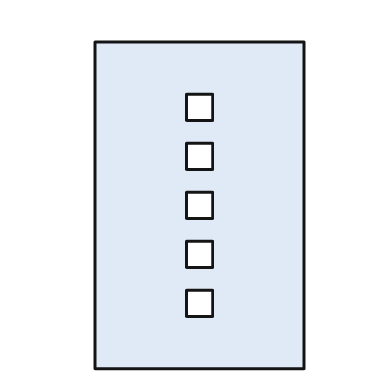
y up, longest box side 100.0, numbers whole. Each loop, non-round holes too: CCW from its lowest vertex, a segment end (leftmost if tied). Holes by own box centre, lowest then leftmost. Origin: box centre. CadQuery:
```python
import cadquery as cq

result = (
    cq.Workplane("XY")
    .moveTo(-32.0, -50.0)
    .lineTo(32.0, -50.0)
    .lineTo(32.0, 50.0)
    .lineTo(-32.0, 50.0)
    .close()
    .moveTo(-4.0, -34.0)
    .lineTo(4.0, -34.0)
    .lineTo(4.0, -26.0)
    .lineTo(-4.0, -26.0)
    .close()
    .moveTo(-4.0, -19.0)
    .lineTo(4.0, -19.0)
    .lineTo(4.0, -11.0)
    .lineTo(-4.0, -11.0)
    .close()
    .moveTo(-4.0, -4.0)
    .lineTo(4.0, -4.0)
    .lineTo(4.0, 4.0)
    .lineTo(-4.0, 4.0)
    .close()
    .moveTo(-4.0, 11.0)
    .lineTo(4.0, 11.0)
    .lineTo(4.0, 19.0)
    .lineTo(-4.0, 19.0)
    .close()
    .moveTo(-4.0, 26.0)
    .lineTo(4.0, 26.0)
    .lineTo(4.0, 34.0)
    .lineTo(-4.0, 34.0)
    .close()
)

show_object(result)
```